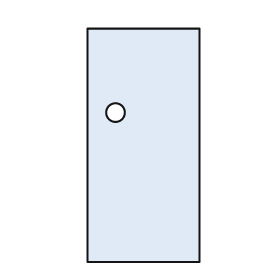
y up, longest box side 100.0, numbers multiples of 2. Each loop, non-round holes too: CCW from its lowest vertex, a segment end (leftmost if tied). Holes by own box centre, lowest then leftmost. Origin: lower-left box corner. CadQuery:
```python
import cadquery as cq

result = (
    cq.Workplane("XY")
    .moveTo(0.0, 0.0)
    .lineTo(48.0, 0.0)
    .lineTo(48.0, 100.0)
    .lineTo(0.0, 100.0)
    .close()
    .moveTo(12.0, 64.0)
    .circle(4.0)
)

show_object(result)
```